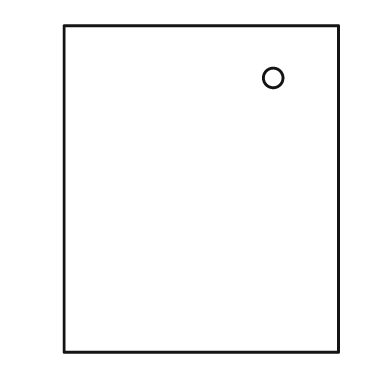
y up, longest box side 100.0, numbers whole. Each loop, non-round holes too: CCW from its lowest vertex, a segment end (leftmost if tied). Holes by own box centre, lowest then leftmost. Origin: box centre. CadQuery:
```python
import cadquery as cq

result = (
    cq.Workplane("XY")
    .moveTo(-42.0, -50.0)
    .lineTo(42.0, -50.0)
    .lineTo(42.0, 50.0)
    .lineTo(-42.0, 50.0)
    .close()
    .moveTo(22.0, 34.0)
    .circle(3.0)
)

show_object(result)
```